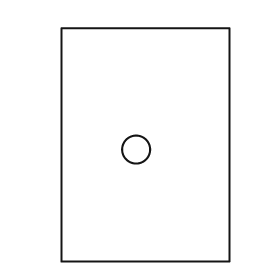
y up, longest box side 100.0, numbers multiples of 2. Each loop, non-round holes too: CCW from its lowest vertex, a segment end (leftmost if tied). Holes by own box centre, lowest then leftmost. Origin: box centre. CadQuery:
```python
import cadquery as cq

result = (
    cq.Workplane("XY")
    .moveTo(-36.0, -50.0)
    .lineTo(36.0, -50.0)
    .lineTo(36.0, 50.0)
    .lineTo(-36.0, 50.0)
    .close()
    .moveTo(-4.0, -2.0)
    .circle(6.0)
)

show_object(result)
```